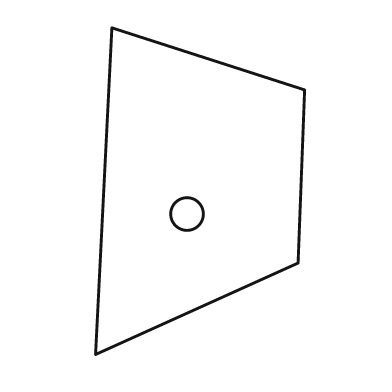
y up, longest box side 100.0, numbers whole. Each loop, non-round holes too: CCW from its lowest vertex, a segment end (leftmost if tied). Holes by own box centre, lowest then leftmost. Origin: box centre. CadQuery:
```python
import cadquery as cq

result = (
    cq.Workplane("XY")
    .moveTo(-32.0, -50.0)
    .lineTo(30.0, -22.0)
    .lineTo(32.0, 31.0)
    .lineTo(-27.0, 50.0)
    .close()
    .moveTo(-4.0, -7.0)
    .circle(5.0)
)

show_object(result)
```